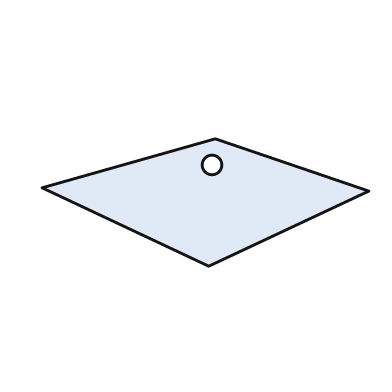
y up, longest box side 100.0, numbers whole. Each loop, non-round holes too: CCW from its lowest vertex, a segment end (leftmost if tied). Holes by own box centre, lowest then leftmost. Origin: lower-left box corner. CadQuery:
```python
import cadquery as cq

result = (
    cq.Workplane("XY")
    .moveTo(51.0, 0.0)
    .lineTo(100.0, 23.0)
    .lineTo(53.0, 39.0)
    .lineTo(0.0, 24.0)
    .close()
    .moveTo(52.0, 31.0)
    .circle(3.0)
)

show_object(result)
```